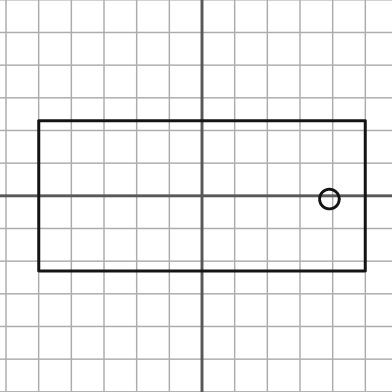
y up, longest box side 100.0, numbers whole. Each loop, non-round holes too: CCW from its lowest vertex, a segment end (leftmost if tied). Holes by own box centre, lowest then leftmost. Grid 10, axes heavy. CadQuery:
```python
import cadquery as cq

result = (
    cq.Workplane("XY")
    .moveTo(-50.0, -23.0)
    .lineTo(50.0, -23.0)
    .lineTo(50.0, 23.0)
    .lineTo(-50.0, 23.0)
    .close()
    .moveTo(39.0, -1.0)
    .circle(3.0)
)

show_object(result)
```